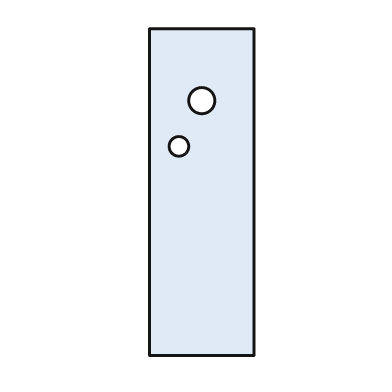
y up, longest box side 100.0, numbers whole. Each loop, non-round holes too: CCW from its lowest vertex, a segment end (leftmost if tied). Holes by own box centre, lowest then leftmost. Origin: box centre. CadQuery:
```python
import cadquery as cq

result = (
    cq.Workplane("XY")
    .moveTo(-16.0, -50.0)
    .lineTo(16.0, -50.0)
    .lineTo(16.0, 50.0)
    .lineTo(-16.0, 50.0)
    .close()
    .moveTo(-7.0, 14.0)
    .circle(3.0)
    .moveTo(0.0, 28.0)
    .circle(4.0)
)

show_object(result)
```